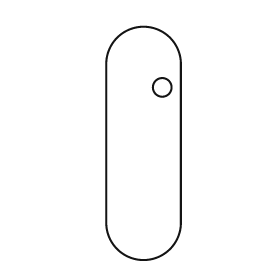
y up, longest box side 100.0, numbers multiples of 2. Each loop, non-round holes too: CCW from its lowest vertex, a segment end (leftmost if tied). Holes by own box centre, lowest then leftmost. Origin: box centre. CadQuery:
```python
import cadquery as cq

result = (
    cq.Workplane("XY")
    .moveTo(-16.0, -34.0)
    .threePointArc((0.0, -50.0), (16.0, -34.0))
    .lineTo(16.0, 34.0)
    .threePointArc((0.0, 50.0), (-16.0, 34.0))
    .close()
    .moveTo(8.0, 24.0)
    .circle(4.0)
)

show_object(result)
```